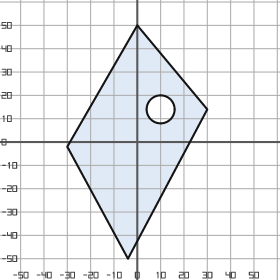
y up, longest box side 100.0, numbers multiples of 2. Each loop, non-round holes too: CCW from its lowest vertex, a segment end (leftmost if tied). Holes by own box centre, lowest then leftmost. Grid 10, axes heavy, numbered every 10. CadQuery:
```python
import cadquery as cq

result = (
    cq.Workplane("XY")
    .moveTo(-4.0, -50.0)
    .lineTo(30.0, 14.0)
    .lineTo(0.0, 50.0)
    .lineTo(-30.0, -2.0)
    .close()
    .moveTo(10.0, 14.0)
    .circle(6.0)
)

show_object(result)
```